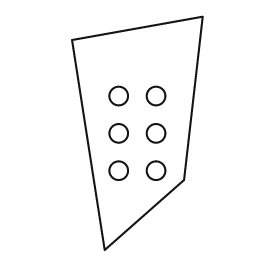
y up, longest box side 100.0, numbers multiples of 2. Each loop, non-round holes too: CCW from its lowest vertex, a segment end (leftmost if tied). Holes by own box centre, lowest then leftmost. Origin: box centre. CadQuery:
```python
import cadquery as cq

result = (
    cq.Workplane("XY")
    .moveTo(-14.0, -50.0)
    .lineTo(20.0, -20.0)
    .lineTo(28.0, 50.0)
    .lineTo(-28.0, 40.0)
    .close()
    .moveTo(-8.0, -16.0)
    .circle(4.0)
    .moveTo(8.0, -16.0)
    .circle(4.0)
    .moveTo(-8.0, 0.0)
    .circle(4.0)
    .moveTo(8.0, 0.0)
    .circle(4.0)
    .moveTo(-8.0, 16.0)
    .circle(4.0)
    .moveTo(8.0, 16.0)
    .circle(4.0)
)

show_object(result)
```